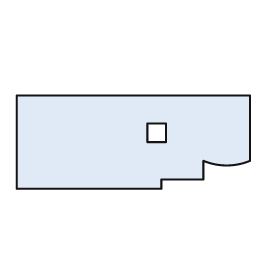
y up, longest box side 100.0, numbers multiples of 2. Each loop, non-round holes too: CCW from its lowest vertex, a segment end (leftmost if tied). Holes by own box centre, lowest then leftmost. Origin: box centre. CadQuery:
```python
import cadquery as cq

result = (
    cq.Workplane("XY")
    .moveTo(-50.0, -20.0)
    .lineTo(12.0, -20.0)
    .lineTo(12.0, -16.0)
    .lineTo(30.0, -16.0)
    .lineTo(30.0, -8.0)
    .threePointArc((40.0, -10.0), (50.0, -8.0))
    .lineTo(50.0, 20.0)
    .lineTo(-50.0, 20.0)
    .close()
    .moveTo(6.0, 0.0)
    .lineTo(14.0, 0.0)
    .lineTo(14.0, 8.0)
    .lineTo(6.0, 8.0)
    .close()
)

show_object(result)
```